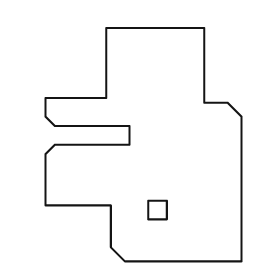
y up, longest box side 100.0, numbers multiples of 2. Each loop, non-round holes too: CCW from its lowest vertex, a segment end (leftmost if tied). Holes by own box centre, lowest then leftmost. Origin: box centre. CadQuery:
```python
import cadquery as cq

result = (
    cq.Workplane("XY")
    .moveTo(-8.0, -50.0)
    .lineTo(42.0, -50.0)
    .lineTo(42.0, 12.0)
    .lineTo(36.0, 18.0)
    .lineTo(26.0, 18.0)
    .lineTo(26.0, 50.0)
    .lineTo(-16.0, 50.0)
    .lineTo(-16.0, 20.0)
    .lineTo(-42.0, 20.0)
    .lineTo(-42.0, 12.0)
    .lineTo(-38.0, 8.0)
    .lineTo(-6.0, 8.0)
    .lineTo(-6.0, 0.0)
    .lineTo(-38.0, 0.0)
    .lineTo(-42.0, -4.0)
    .lineTo(-42.0, -26.0)
    .lineTo(-14.0, -26.0)
    .lineTo(-14.0, -44.0)
    .close()
    .moveTo(2.0, -32.0)
    .lineTo(10.0, -32.0)
    .lineTo(10.0, -24.0)
    .lineTo(2.0, -24.0)
    .close()
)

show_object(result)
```